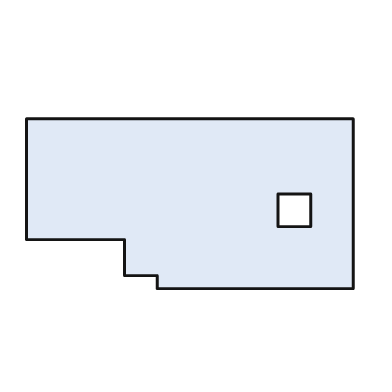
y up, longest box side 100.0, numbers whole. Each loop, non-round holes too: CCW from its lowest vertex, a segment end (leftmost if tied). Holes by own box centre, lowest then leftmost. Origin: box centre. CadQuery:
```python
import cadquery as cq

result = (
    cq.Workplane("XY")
    .moveTo(-10.0, -26.0)
    .lineTo(50.0, -26.0)
    .lineTo(50.0, 26.0)
    .lineTo(-50.0, 26.0)
    .lineTo(-50.0, -11.0)
    .lineTo(-20.0, -11.0)
    .lineTo(-20.0, -22.0)
    .lineTo(-10.0, -22.0)
    .close()
    .moveTo(27.0, -7.0)
    .lineTo(37.0, -7.0)
    .lineTo(37.0, 3.0)
    .lineTo(27.0, 3.0)
    .close()
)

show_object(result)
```